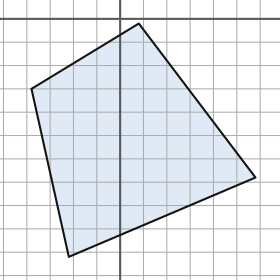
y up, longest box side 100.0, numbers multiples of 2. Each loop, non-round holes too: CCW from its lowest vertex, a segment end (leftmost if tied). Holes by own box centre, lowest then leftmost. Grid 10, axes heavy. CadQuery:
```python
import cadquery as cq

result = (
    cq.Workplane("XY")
    .moveTo(-22.0, -102.0)
    .lineTo(58.0, -68.0)
    .lineTo(8.0, -2.0)
    .lineTo(-38.0, -30.0)
    .close()
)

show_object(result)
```